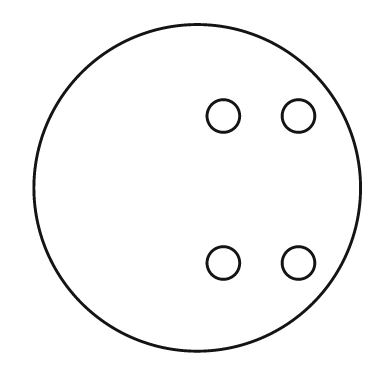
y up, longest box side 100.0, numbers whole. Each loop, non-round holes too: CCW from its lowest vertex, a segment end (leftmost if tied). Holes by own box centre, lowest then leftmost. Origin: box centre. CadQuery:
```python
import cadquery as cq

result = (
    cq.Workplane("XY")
    .moveTo(0.0, 0.0)
    .circle(50.0)
    .moveTo(8.0, -23.0)
    .circle(5.0)
    .moveTo(31.0, -23.0)
    .circle(5.0)
    .moveTo(8.0, 22.0)
    .circle(5.0)
    .moveTo(31.0, 22.0)
    .circle(5.0)
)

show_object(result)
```